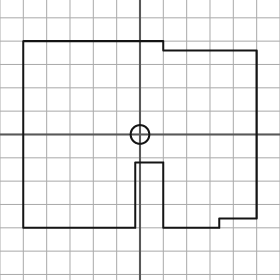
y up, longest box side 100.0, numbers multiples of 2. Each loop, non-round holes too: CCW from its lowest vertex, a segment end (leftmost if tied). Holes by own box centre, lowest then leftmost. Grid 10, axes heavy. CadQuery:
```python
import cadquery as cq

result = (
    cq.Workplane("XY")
    .moveTo(-50.0, -40.0)
    .lineTo(-2.0, -40.0)
    .lineTo(-2.0, -12.0)
    .lineTo(10.0, -12.0)
    .lineTo(10.0, -40.0)
    .lineTo(34.0, -40.0)
    .lineTo(34.0, -36.0)
    .lineTo(50.0, -36.0)
    .lineTo(50.0, 36.0)
    .lineTo(10.0, 36.0)
    .lineTo(10.0, 40.0)
    .lineTo(-50.0, 40.0)
    .close()
    .moveTo(0.0, 0.0)
    .circle(4.0)
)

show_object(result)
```